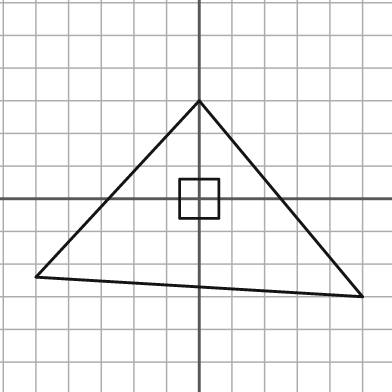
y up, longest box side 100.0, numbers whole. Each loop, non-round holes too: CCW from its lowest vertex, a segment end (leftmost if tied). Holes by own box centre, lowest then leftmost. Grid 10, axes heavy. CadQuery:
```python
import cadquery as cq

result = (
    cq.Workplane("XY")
    .moveTo(50.0, -30.0)
    .lineTo(0.0, 30.0)
    .lineTo(-50.0, -24.0)
    .close()
    .moveTo(-6.0, -6.0)
    .lineTo(6.0, -6.0)
    .lineTo(6.0, 6.0)
    .lineTo(-6.0, 6.0)
    .close()
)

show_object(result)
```